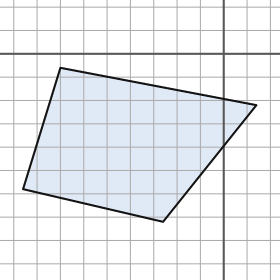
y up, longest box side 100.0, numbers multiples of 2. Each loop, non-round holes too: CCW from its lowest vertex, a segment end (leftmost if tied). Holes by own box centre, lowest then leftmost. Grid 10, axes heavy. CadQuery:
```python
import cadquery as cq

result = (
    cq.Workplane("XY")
    .moveTo(-26.0, -72.0)
    .lineTo(14.0, -22.0)
    .lineTo(-70.0, -6.0)
    .lineTo(-86.0, -58.0)
    .close()
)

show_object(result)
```